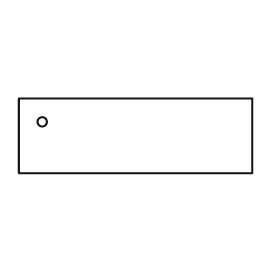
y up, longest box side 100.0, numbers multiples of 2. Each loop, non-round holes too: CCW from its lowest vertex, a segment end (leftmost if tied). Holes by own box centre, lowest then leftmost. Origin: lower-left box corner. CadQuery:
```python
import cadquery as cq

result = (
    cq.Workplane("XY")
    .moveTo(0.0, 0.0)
    .lineTo(100.0, 0.0)
    .lineTo(100.0, 32.0)
    .lineTo(0.0, 32.0)
    .close()
    .moveTo(10.0, 22.0)
    .circle(2.0)
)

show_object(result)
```